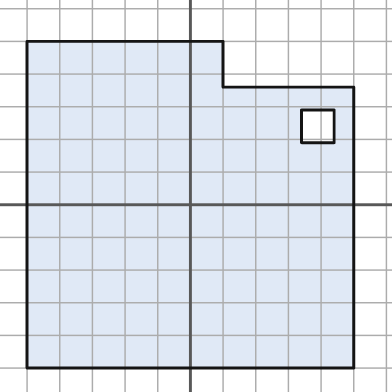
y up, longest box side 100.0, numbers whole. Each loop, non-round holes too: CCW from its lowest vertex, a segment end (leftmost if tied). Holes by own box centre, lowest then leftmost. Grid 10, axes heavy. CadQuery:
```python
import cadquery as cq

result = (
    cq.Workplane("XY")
    .moveTo(-50.0, -50.0)
    .lineTo(50.0, -50.0)
    .lineTo(50.0, 36.0)
    .lineTo(10.0, 36.0)
    .lineTo(10.0, 50.0)
    .lineTo(-50.0, 50.0)
    .close()
    .moveTo(34.0, 19.0)
    .lineTo(44.0, 19.0)
    .lineTo(44.0, 29.0)
    .lineTo(34.0, 29.0)
    .close()
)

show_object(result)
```